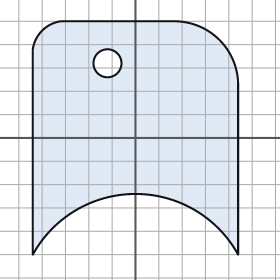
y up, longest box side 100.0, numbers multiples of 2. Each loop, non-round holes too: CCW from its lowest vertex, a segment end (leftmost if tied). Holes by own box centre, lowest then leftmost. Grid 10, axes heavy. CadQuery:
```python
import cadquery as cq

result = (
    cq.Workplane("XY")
    .moveTo(-44.0, -50.0)
    .threePointArc((0.0, -24.0), (44.0, -50.0))
    .lineTo(44.0, 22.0)
    .threePointArc((36.0, 42.0), (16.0, 50.0))
    .lineTo(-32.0, 50.0)
    .threePointArc((-40.0, 46.0), (-44.0, 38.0))
    .close()
    .moveTo(-12.0, 32.0)
    .circle(6.0)
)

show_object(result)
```